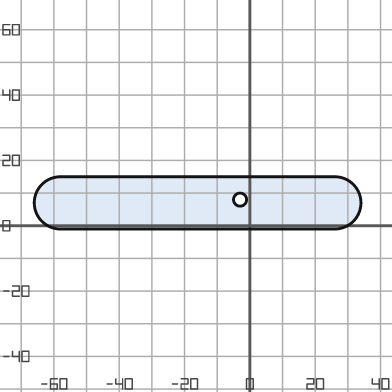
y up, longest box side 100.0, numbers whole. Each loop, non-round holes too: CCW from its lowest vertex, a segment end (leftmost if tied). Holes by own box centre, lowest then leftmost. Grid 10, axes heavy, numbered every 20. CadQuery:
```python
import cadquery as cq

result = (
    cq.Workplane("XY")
    .moveTo(-58.0, -1.0)
    .lineTo(26.0, -1.0)
    .threePointArc((34.0, 7.0), (26.0, 15.0))
    .lineTo(-58.0, 15.0)
    .threePointArc((-66.0, 7.0), (-58.0, -1.0))
    .close()
    .moveTo(-3.0, 8.0)
    .circle(2.0)
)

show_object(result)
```